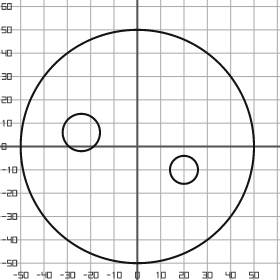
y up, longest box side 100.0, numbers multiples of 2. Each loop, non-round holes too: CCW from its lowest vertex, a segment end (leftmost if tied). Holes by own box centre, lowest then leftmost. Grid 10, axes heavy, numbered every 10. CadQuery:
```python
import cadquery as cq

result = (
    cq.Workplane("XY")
    .moveTo(0.0, 0.0)
    .circle(50.0)
    .moveTo(20.0, -10.0)
    .circle(6.0)
    .moveTo(-24.0, 6.0)
    .circle(8.0)
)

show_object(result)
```